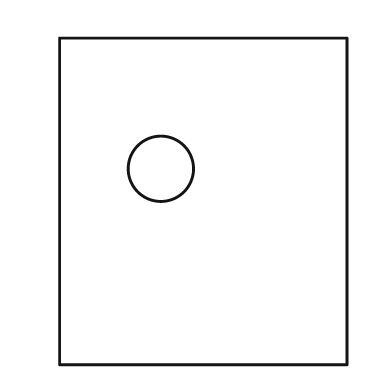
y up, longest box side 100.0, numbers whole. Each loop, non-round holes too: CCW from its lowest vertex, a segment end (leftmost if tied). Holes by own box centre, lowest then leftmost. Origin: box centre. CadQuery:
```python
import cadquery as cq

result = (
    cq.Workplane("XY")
    .moveTo(-44.0, -50.0)
    .lineTo(44.0, -50.0)
    .lineTo(44.0, 50.0)
    .lineTo(-44.0, 50.0)
    .close()
    .moveTo(-13.0, 10.0)
    .circle(10.0)
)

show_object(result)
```